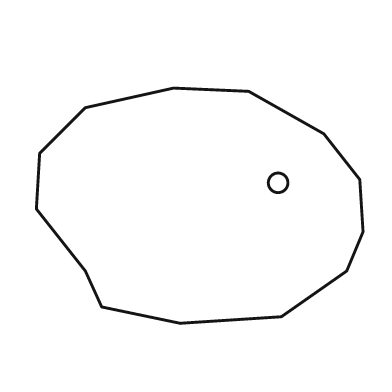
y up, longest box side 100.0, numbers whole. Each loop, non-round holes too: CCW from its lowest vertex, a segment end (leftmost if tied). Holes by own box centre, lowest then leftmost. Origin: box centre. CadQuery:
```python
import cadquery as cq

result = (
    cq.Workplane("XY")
    .moveTo(-6.0, -36.0)
    .lineTo(25.0, -34.0)
    .lineTo(45.0, -20.0)
    .lineTo(50.0, -8.0)
    .lineTo(49.0, 8.0)
    .lineTo(38.0, 22.0)
    .lineTo(15.0, 35.0)
    .lineTo(-8.0, 36.0)
    .lineTo(-35.0, 30.0)
    .lineTo(-49.0, 16.0)
    .lineTo(-50.0, -1.0)
    .lineTo(-35.0, -20.0)
    .lineTo(-30.0, -31.0)
    .close()
    .moveTo(24.0, 7.0)
    .circle(3.0)
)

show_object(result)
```